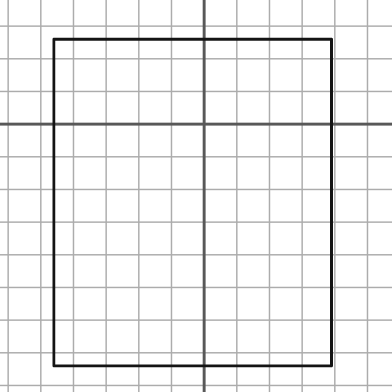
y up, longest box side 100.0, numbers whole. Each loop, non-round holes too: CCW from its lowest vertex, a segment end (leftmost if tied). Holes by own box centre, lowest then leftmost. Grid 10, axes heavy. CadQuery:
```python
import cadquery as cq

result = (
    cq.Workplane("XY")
    .moveTo(-46.0, -74.0)
    .lineTo(39.0, -74.0)
    .lineTo(39.0, 26.0)
    .lineTo(-46.0, 26.0)
    .close()
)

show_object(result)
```